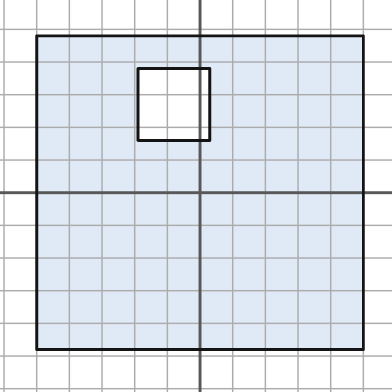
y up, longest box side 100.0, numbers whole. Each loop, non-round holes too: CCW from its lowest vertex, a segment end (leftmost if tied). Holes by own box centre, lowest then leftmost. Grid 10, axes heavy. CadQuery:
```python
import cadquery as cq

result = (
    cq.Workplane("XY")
    .moveTo(-50.0, -48.0)
    .lineTo(50.0, -48.0)
    .lineTo(50.0, 48.0)
    .lineTo(-50.0, 48.0)
    .close()
    .moveTo(-19.0, 16.0)
    .lineTo(3.0, 16.0)
    .lineTo(3.0, 38.0)
    .lineTo(-19.0, 38.0)
    .close()
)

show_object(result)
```